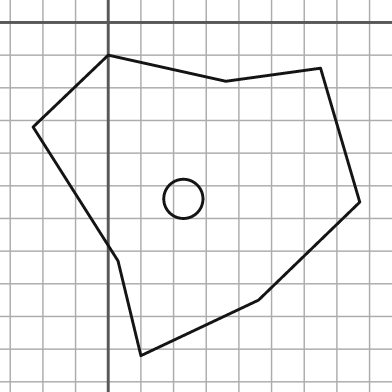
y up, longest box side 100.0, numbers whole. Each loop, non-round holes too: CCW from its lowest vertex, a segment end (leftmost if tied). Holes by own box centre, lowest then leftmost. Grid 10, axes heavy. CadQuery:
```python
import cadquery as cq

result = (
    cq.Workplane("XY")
    .moveTo(10.0, -102.0)
    .lineTo(46.0, -85.0)
    .lineTo(77.0, -55.0)
    .lineTo(65.0, -14.0)
    .lineTo(36.0, -18.0)
    .lineTo(0.0, -10.0)
    .lineTo(-23.0, -32.0)
    .lineTo(3.0, -73.0)
    .close()
    .moveTo(23.0, -54.0)
    .circle(6.0)
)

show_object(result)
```